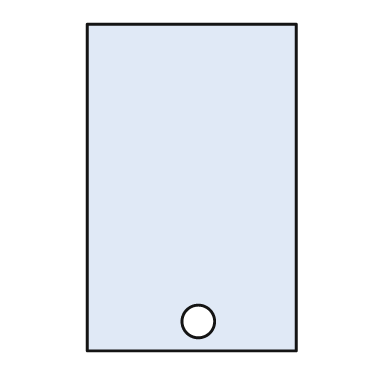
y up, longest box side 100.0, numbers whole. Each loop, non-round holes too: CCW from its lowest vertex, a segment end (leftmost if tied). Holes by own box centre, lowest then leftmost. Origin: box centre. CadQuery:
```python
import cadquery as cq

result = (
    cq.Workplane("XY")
    .moveTo(-32.0, -50.0)
    .lineTo(32.0, -50.0)
    .lineTo(32.0, 50.0)
    .lineTo(-32.0, 50.0)
    .close()
    .moveTo(2.0, -41.0)
    .circle(5.0)
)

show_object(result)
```